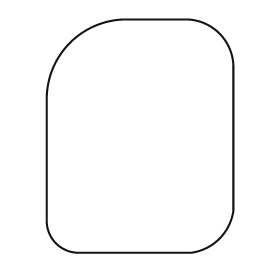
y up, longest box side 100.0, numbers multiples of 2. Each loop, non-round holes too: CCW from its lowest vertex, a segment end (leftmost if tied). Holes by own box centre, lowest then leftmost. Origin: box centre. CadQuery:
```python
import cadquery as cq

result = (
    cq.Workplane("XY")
    .moveTo(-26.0, -50.0)
    .lineTo(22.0, -50.0)
    .threePointArc((34.0, -44.0), (40.0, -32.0))
    .lineTo(40.0, 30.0)
    .threePointArc((34.0, 44.0), (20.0, 50.0))
    .lineTo(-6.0, 50.0)
    .threePointArc((-30.0, 40.0), (-40.0, 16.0))
    .lineTo(-40.0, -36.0)
    .threePointArc((-36.0, -46.0), (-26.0, -50.0))
    .close()
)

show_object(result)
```